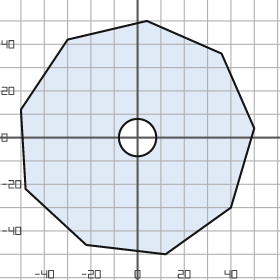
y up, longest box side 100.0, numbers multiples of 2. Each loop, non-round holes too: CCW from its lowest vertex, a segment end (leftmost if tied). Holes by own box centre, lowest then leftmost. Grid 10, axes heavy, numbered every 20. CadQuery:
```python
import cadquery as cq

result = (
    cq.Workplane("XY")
    .moveTo(12.0, -50.0)
    .lineTo(40.0, -30.0)
    .lineTo(50.0, 4.0)
    .lineTo(36.0, 36.0)
    .lineTo(4.0, 50.0)
    .lineTo(-30.0, 42.0)
    .lineTo(-50.0, 12.0)
    .lineTo(-48.0, -22.0)
    .lineTo(-22.0, -46.0)
    .close()
    .moveTo(0.0, 0.0)
    .circle(8.0)
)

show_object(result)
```